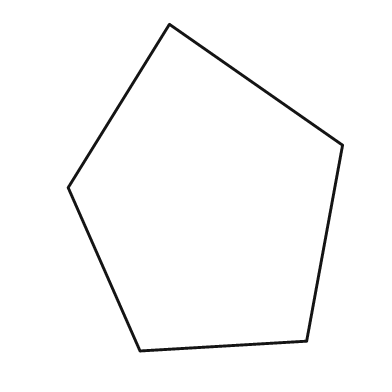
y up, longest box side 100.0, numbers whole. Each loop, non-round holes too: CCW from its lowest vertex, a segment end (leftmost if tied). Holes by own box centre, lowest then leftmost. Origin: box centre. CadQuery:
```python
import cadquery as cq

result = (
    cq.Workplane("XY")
    .moveTo(-20.0, -50.0)
    .lineTo(31.0, -47.0)
    .lineTo(42.0, 13.0)
    .lineTo(-11.0, 50.0)
    .lineTo(-42.0, 0.0)
    .close()
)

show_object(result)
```